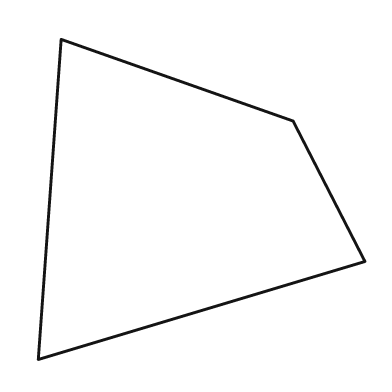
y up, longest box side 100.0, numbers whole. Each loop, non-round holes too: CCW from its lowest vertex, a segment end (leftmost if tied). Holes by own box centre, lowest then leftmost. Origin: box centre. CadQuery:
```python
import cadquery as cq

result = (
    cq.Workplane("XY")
    .moveTo(-50.0, -49.0)
    .lineTo(50.0, -19.0)
    .lineTo(28.0, 24.0)
    .lineTo(-43.0, 49.0)
    .close()
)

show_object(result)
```